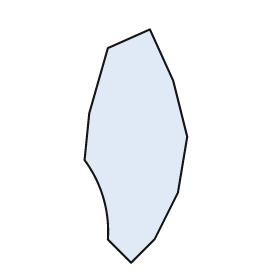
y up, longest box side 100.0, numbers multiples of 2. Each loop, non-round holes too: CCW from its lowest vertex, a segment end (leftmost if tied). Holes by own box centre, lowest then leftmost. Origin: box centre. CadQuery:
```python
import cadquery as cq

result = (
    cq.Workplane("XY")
    .moveTo(-2.0, -50.0)
    .lineTo(8.0, -40.0)
    .lineTo(18.0, -20.0)
    .lineTo(22.0, 4.0)
    .lineTo(16.0, 28.0)
    .lineTo(6.0, 50.0)
    .lineTo(-12.0, 42.0)
    .lineTo(-20.0, 14.0)
    .lineTo(-22.0, -6.0)
    .threePointArc((-14.0, -22.0), (-12.0, -40.0))
    .close()
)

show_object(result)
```